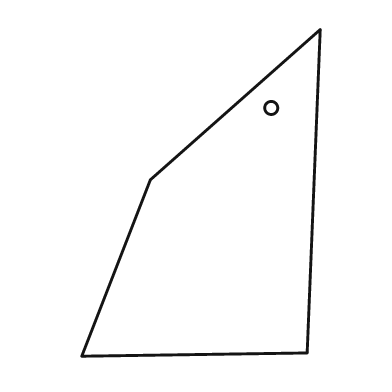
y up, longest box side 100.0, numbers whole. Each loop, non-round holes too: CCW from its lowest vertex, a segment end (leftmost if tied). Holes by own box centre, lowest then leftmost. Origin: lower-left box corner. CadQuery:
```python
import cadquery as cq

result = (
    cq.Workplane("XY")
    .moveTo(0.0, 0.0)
    .lineTo(69.0, 1.0)
    .lineTo(73.0, 100.0)
    .lineTo(21.0, 54.0)
    .close()
    .moveTo(58.0, 76.0)
    .circle(2.0)
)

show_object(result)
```